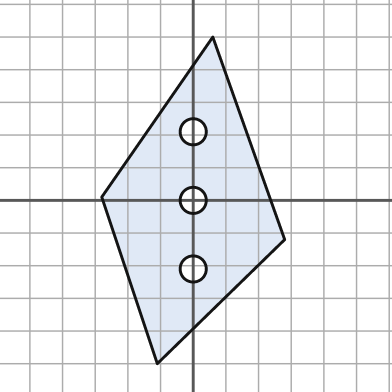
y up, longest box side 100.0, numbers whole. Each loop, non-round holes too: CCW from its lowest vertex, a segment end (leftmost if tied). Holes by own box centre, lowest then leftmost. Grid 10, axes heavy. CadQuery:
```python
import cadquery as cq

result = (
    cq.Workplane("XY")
    .moveTo(-11.0, -50.0)
    .lineTo(28.0, -12.0)
    .lineTo(6.0, 50.0)
    .lineTo(-28.0, 1.0)
    .close()
    .moveTo(0.0, -21.0)
    .circle(4.0)
    .moveTo(0.0, 0.0)
    .circle(4.0)
    .moveTo(0.0, 21.0)
    .circle(4.0)
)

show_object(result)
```